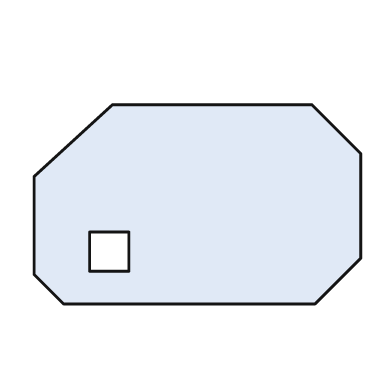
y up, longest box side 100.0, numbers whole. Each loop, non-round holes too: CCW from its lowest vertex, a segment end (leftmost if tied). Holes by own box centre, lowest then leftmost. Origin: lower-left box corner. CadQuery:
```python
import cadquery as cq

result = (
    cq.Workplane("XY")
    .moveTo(9.0, 0.0)
    .lineTo(86.0, 0.0)
    .lineTo(100.0, 14.0)
    .lineTo(100.0, 46.0)
    .lineTo(85.0, 61.0)
    .lineTo(24.0, 61.0)
    .lineTo(0.0, 39.0)
    .lineTo(0.0, 9.0)
    .close()
    .moveTo(17.0, 10.0)
    .lineTo(29.0, 10.0)
    .lineTo(29.0, 22.0)
    .lineTo(17.0, 22.0)
    .close()
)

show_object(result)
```